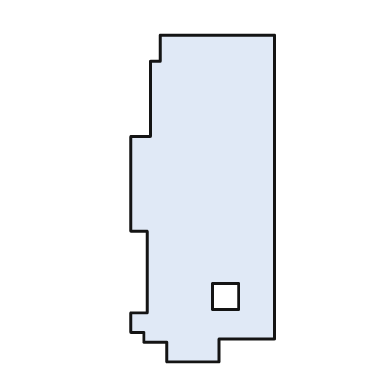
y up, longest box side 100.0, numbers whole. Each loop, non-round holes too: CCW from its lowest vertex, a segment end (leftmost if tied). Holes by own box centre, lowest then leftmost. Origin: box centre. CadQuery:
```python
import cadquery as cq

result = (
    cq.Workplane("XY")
    .moveTo(-11.0, -50.0)
    .lineTo(5.0, -50.0)
    .lineTo(5.0, -43.0)
    .lineTo(22.0, -43.0)
    .lineTo(22.0, 50.0)
    .lineTo(-13.0, 50.0)
    .lineTo(-13.0, 42.0)
    .lineTo(-16.0, 42.0)
    .lineTo(-16.0, 19.0)
    .lineTo(-22.0, 19.0)
    .lineTo(-22.0, -10.0)
    .lineTo(-17.0, -10.0)
    .lineTo(-17.0, -35.0)
    .lineTo(-22.0, -35.0)
    .lineTo(-22.0, -41.0)
    .lineTo(-18.0, -41.0)
    .lineTo(-18.0, -44.0)
    .lineTo(-11.0, -44.0)
    .close()
    .moveTo(3.0, -34.0)
    .lineTo(11.0, -34.0)
    .lineTo(11.0, -26.0)
    .lineTo(3.0, -26.0)
    .close()
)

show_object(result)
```